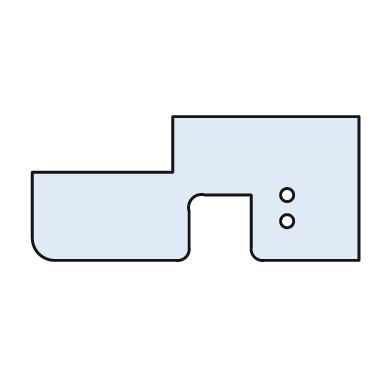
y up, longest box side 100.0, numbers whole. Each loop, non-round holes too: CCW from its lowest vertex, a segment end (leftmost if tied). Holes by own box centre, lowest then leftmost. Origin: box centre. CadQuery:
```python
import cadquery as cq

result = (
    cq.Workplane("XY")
    .moveTo(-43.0, -22.0)
    .lineTo(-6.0, -22.0)
    .threePointArc((-3.0, -21.0), (-2.0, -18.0))
    .lineTo(-2.0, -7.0)
    .threePointArc((-1.0, -3.0), (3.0, -2.0))
    .lineTo(17.0, -2.0)
    .lineTo(17.0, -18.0)
    .threePointArc((18.0, -21.0), (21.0, -22.0))
    .lineTo(50.0, -22.0)
    .lineTo(50.0, 22.0)
    .lineTo(-7.0, 22.0)
    .lineTo(-7.0, 5.0)
    .lineTo(-50.0, 5.0)
    .lineTo(-50.0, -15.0)
    .threePointArc((-48.0, -20.0), (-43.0, -22.0))
    .close()
    .moveTo(28.0, -10.0)
    .circle(2.0)
    .moveTo(28.0, -2.0)
    .circle(2.0)
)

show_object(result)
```